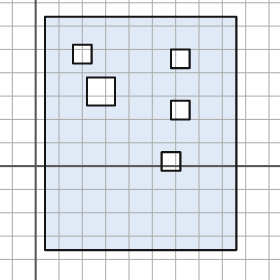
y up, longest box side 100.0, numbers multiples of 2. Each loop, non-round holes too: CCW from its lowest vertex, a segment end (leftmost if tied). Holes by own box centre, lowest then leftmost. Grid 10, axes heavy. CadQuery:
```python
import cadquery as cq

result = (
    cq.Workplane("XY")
    .moveTo(4.0, -36.0)
    .lineTo(86.0, -36.0)
    .lineTo(86.0, 64.0)
    .lineTo(4.0, 64.0)
    .close()
    .moveTo(54.0, -2.0)
    .lineTo(62.0, -2.0)
    .lineTo(62.0, 6.0)
    .lineTo(54.0, 6.0)
    .close()
    .moveTo(58.0, 20.0)
    .lineTo(66.0, 20.0)
    .lineTo(66.0, 28.0)
    .lineTo(58.0, 28.0)
    .close()
    .moveTo(22.0, 26.0)
    .lineTo(34.0, 26.0)
    .lineTo(34.0, 38.0)
    .lineTo(22.0, 38.0)
    .close()
    .moveTo(58.0, 42.0)
    .lineTo(66.0, 42.0)
    .lineTo(66.0, 50.0)
    .lineTo(58.0, 50.0)
    .close()
    .moveTo(16.0, 44.0)
    .lineTo(24.0, 44.0)
    .lineTo(24.0, 52.0)
    .lineTo(16.0, 52.0)
    .close()
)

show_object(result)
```